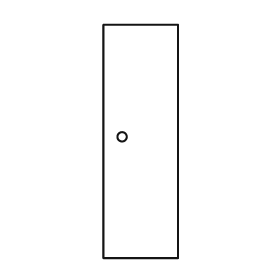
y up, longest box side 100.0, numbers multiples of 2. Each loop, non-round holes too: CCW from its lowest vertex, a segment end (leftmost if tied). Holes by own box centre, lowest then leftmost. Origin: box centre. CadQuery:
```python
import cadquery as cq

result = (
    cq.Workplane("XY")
    .moveTo(-16.0, -50.0)
    .lineTo(16.0, -50.0)
    .lineTo(16.0, 50.0)
    .lineTo(-16.0, 50.0)
    .close()
    .moveTo(-8.0, 2.0)
    .circle(2.0)
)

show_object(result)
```